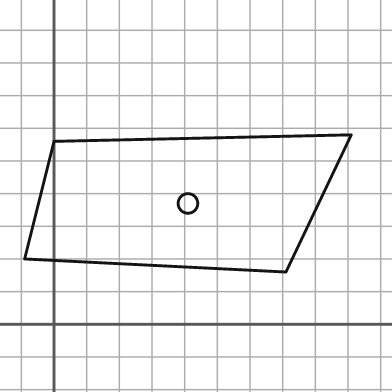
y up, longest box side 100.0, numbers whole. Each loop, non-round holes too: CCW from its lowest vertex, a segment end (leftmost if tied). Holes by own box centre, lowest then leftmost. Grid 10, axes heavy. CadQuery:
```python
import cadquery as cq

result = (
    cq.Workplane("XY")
    .moveTo(71.0, 16.0)
    .lineTo(91.0, 58.0)
    .lineTo(0.0, 56.0)
    .lineTo(-9.0, 20.0)
    .close()
    .moveTo(41.0, 37.0)
    .circle(3.0)
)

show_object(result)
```